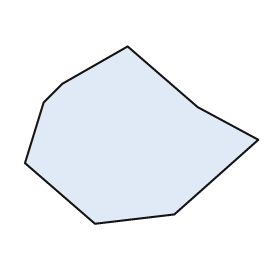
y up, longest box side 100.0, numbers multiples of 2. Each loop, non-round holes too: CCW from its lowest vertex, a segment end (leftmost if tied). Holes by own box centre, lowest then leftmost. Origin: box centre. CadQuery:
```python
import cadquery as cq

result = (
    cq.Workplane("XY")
    .moveTo(-20.0, -38.0)
    .lineTo(14.0, -34.0)
    .lineTo(50.0, -2.0)
    .lineTo(24.0, 12.0)
    .lineTo(-6.0, 38.0)
    .lineTo(-34.0, 22.0)
    .lineTo(-42.0, 14.0)
    .lineTo(-50.0, -12.0)
    .close()
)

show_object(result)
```